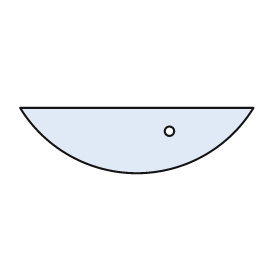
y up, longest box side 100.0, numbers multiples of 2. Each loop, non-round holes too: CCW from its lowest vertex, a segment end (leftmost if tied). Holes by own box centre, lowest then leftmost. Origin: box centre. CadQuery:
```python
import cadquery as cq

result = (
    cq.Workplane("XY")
    .moveTo(-50.0, 14.0)
    .threePointArc((0.0, -14.0), (50.0, 14.0))
    .close()
    .moveTo(14.0, 4.0)
    .circle(2.0)
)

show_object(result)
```